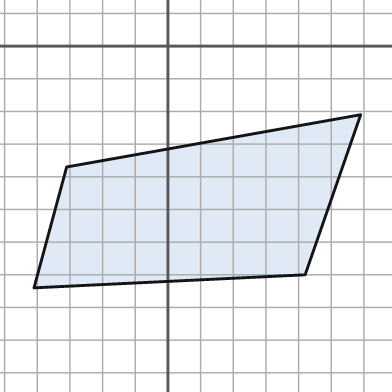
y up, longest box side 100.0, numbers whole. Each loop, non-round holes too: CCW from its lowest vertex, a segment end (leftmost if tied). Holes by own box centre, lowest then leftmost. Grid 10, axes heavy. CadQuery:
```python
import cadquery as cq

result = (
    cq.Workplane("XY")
    .moveTo(-41.0, -74.0)
    .lineTo(42.0, -70.0)
    .lineTo(59.0, -21.0)
    .lineTo(-31.0, -37.0)
    .close()
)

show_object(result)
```